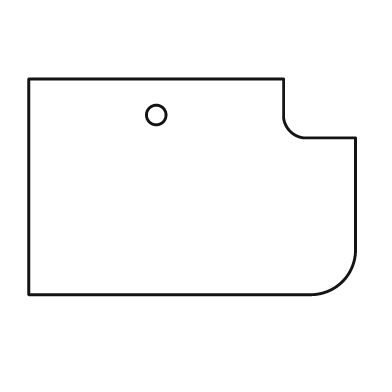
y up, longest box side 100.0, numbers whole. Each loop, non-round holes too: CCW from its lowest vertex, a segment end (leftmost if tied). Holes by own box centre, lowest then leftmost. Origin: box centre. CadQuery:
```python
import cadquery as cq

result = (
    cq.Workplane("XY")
    .moveTo(-50.0, -33.0)
    .lineTo(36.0, -33.0)
    .threePointArc((46.0, -29.0), (50.0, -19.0))
    .lineTo(50.0, 15.0)
    .lineTo(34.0, 15.0)
    .threePointArc((30.0, 17.0), (28.0, 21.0))
    .lineTo(28.0, 33.0)
    .lineTo(-50.0, 33.0)
    .close()
    .moveTo(-11.0, 22.0)
    .circle(3.0)
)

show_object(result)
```